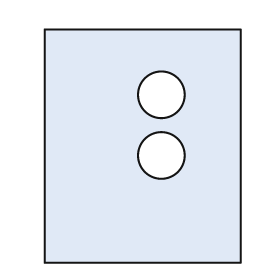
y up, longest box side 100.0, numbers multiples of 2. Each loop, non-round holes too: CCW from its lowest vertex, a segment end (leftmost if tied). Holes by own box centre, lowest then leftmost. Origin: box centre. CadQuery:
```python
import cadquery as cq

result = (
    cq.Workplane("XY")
    .moveTo(-42.0, -50.0)
    .lineTo(42.0, -50.0)
    .lineTo(42.0, 50.0)
    .lineTo(-42.0, 50.0)
    .close()
    .moveTo(8.0, -4.0)
    .circle(10.0)
    .moveTo(8.0, 22.0)
    .circle(10.0)
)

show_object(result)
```